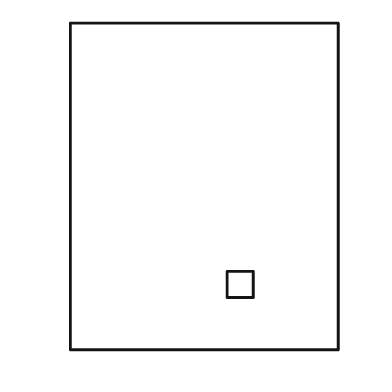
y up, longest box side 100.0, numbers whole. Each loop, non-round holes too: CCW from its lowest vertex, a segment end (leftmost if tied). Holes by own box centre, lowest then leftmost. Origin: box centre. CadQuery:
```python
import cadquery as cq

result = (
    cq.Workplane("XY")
    .moveTo(-41.0, -50.0)
    .lineTo(41.0, -50.0)
    .lineTo(41.0, 50.0)
    .lineTo(-41.0, 50.0)
    .close()
    .moveTo(7.0, -34.0)
    .lineTo(15.0, -34.0)
    .lineTo(15.0, -26.0)
    .lineTo(7.0, -26.0)
    .close()
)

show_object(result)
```